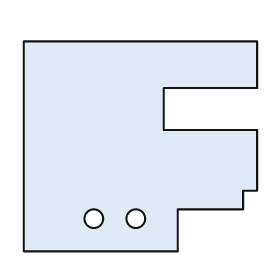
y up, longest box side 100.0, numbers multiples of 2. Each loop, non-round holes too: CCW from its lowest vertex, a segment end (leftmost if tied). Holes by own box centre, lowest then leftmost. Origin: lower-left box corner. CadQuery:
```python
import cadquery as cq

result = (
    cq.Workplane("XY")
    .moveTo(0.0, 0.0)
    .lineTo(66.0, 0.0)
    .lineTo(66.0, 18.0)
    .lineTo(94.0, 18.0)
    .lineTo(94.0, 26.0)
    .lineTo(100.0, 26.0)
    .lineTo(100.0, 52.0)
    .lineTo(60.0, 52.0)
    .lineTo(60.0, 70.0)
    .lineTo(100.0, 70.0)
    .lineTo(100.0, 90.0)
    .lineTo(0.0, 90.0)
    .close()
    .moveTo(30.0, 14.0)
    .circle(4.0)
    .moveTo(48.0, 14.0)
    .circle(4.0)
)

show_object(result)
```